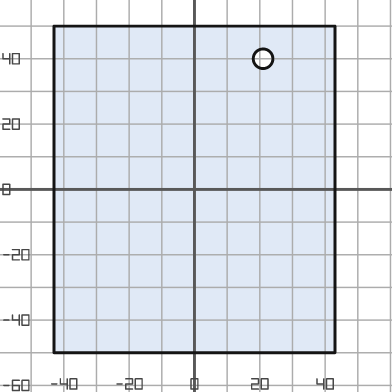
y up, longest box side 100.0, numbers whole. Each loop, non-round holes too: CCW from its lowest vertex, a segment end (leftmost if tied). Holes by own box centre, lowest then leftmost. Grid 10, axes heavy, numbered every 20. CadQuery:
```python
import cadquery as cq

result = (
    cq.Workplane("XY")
    .moveTo(-43.0, -50.0)
    .lineTo(43.0, -50.0)
    .lineTo(43.0, 50.0)
    .lineTo(-43.0, 50.0)
    .close()
    .moveTo(21.0, 40.0)
    .circle(3.0)
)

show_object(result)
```